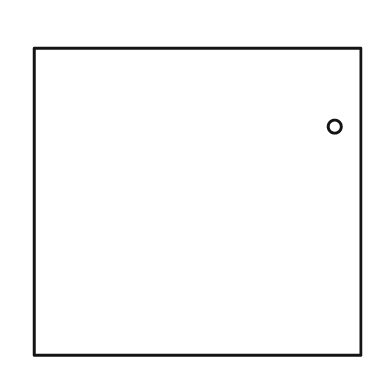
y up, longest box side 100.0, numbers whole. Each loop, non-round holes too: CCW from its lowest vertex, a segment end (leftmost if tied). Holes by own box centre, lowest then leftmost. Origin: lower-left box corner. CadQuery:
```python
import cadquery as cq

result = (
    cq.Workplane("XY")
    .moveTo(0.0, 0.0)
    .lineTo(100.0, 0.0)
    .lineTo(100.0, 94.0)
    .lineTo(0.0, 94.0)
    .close()
    .moveTo(92.0, 70.0)
    .circle(2.0)
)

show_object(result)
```